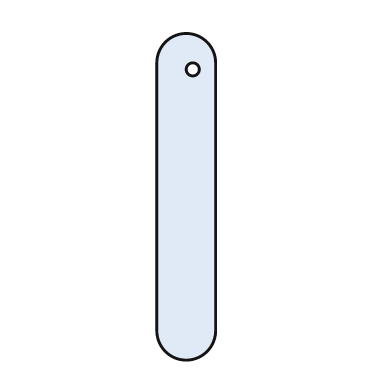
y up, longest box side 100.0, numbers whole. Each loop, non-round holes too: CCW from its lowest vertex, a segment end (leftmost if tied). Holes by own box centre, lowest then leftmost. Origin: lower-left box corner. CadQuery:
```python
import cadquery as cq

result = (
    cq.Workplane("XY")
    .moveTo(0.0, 9.0)
    .threePointArc((9.0, 0.0), (18.0, 9.0))
    .lineTo(18.0, 91.0)
    .threePointArc((9.0, 100.0), (0.0, 91.0))
    .close()
    .moveTo(11.0, 89.0)
    .circle(2.0)
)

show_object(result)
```